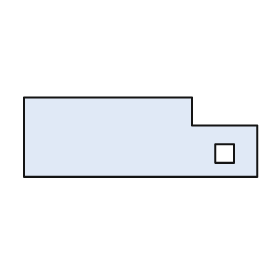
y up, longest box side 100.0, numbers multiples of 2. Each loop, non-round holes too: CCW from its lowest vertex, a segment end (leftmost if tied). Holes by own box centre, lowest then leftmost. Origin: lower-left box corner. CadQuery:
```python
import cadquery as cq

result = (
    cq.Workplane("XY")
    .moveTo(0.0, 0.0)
    .lineTo(100.0, 0.0)
    .lineTo(100.0, 22.0)
    .lineTo(72.0, 22.0)
    .lineTo(72.0, 34.0)
    .lineTo(0.0, 34.0)
    .close()
    .moveTo(82.0, 6.0)
    .lineTo(90.0, 6.0)
    .lineTo(90.0, 14.0)
    .lineTo(82.0, 14.0)
    .close()
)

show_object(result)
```